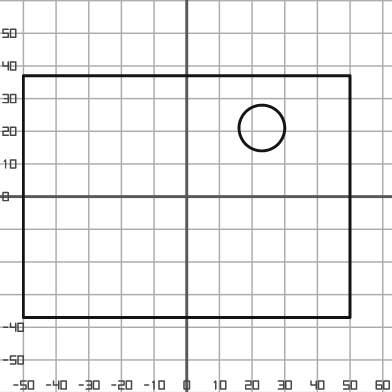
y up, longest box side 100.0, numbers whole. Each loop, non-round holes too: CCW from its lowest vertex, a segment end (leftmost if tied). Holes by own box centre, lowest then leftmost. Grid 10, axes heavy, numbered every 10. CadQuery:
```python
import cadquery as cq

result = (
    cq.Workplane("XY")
    .moveTo(-50.0, -37.0)
    .lineTo(50.0, -37.0)
    .lineTo(50.0, 37.0)
    .lineTo(-50.0, 37.0)
    .close()
    .moveTo(23.0, 21.0)
    .circle(7.0)
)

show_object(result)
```